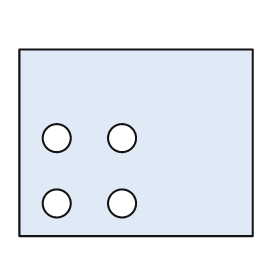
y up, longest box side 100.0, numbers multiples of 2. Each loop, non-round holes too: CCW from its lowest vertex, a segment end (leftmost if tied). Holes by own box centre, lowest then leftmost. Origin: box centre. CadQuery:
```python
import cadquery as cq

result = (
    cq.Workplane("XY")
    .moveTo(-50.0, -40.0)
    .lineTo(50.0, -40.0)
    .lineTo(50.0, 40.0)
    .lineTo(-50.0, 40.0)
    .close()
    .moveTo(-34.0, -26.0)
    .circle(6.0)
    .moveTo(-6.0, -26.0)
    .circle(6.0)
    .moveTo(-34.0, 2.0)
    .circle(6.0)
    .moveTo(-6.0, 2.0)
    .circle(6.0)
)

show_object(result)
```